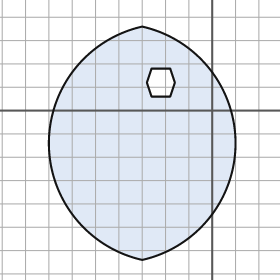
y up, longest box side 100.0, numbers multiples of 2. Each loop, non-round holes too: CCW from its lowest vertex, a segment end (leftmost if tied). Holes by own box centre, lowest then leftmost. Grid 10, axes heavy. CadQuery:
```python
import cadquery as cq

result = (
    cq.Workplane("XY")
    .moveTo(-30.0, -64.0)
    .threePointArc((10.0, -14.0), (-30.0, 36.0))
    .threePointArc((-70.0, -14.0), (-30.0, -64.0))
    .close()
    .moveTo(-26.0, 6.0)
    .lineTo(-18.0, 6.0)
    .lineTo(-16.0, 12.0)
    .lineTo(-18.0, 18.0)
    .lineTo(-26.0, 18.0)
    .lineTo(-28.0, 12.0)
    .close()
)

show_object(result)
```